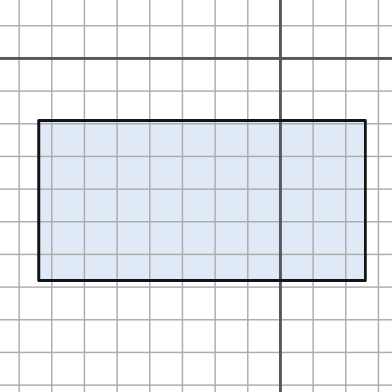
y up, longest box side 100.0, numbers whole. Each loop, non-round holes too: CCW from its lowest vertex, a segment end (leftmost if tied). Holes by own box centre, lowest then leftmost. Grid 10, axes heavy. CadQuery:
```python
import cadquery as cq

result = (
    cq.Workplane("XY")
    .moveTo(-74.0, -68.0)
    .lineTo(26.0, -68.0)
    .lineTo(26.0, -19.0)
    .lineTo(-74.0, -19.0)
    .close()
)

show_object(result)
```